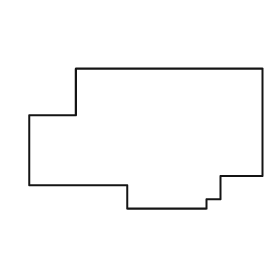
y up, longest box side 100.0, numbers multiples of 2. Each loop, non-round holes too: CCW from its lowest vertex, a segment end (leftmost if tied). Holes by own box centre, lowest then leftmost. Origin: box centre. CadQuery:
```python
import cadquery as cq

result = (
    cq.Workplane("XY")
    .moveTo(-8.0, -30.0)
    .lineTo(26.0, -30.0)
    .lineTo(26.0, -26.0)
    .lineTo(32.0, -26.0)
    .lineTo(32.0, -16.0)
    .lineTo(50.0, -16.0)
    .lineTo(50.0, 30.0)
    .lineTo(-30.0, 30.0)
    .lineTo(-30.0, 10.0)
    .lineTo(-50.0, 10.0)
    .lineTo(-50.0, -20.0)
    .lineTo(-8.0, -20.0)
    .close()
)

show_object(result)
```